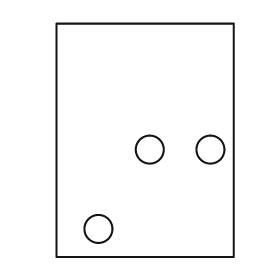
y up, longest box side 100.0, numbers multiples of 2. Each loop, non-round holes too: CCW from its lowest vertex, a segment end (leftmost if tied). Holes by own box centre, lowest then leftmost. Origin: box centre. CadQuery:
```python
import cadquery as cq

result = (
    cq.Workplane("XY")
    .moveTo(-38.0, -50.0)
    .lineTo(38.0, -50.0)
    .lineTo(38.0, 50.0)
    .lineTo(-38.0, 50.0)
    .close()
    .moveTo(-20.0, -38.0)
    .circle(6.0)
    .moveTo(2.0, -4.0)
    .circle(6.0)
    .moveTo(28.0, -4.0)
    .circle(6.0)
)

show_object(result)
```